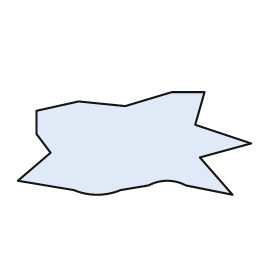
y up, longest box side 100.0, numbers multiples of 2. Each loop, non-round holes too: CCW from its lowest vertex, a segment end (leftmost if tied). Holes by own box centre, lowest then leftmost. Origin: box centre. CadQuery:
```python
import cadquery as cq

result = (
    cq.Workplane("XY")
    .moveTo(42.0, -22.0)
    .lineTo(28.0, -6.0)
    .lineTo(50.0, 0.0)
    .lineTo(26.0, 8.0)
    .lineTo(30.0, 22.0)
    .lineTo(16.0, 22.0)
    .lineTo(-4.0, 16.0)
    .lineTo(-24.0, 18.0)
    .lineTo(-42.0, 14.0)
    .lineTo(-42.0, 4.0)
    .lineTo(-36.0, -4.0)
    .lineTo(-50.0, -16.0)
    .lineTo(-26.0, -20.0)
    .threePointArc((-16.0, -22.0), (-6.0, -20.0))
    .lineTo(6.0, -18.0)
    .threePointArc((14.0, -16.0), (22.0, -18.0))
    .close()
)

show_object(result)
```